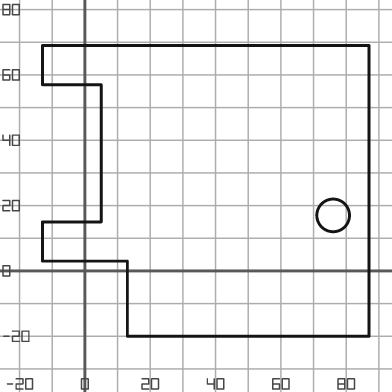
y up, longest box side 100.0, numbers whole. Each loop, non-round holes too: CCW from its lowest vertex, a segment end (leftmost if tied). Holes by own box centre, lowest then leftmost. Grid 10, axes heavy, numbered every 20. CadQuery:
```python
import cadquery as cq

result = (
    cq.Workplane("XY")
    .moveTo(13.0, -20.0)
    .lineTo(87.0, -20.0)
    .lineTo(87.0, 69.0)
    .lineTo(-13.0, 69.0)
    .lineTo(-13.0, 57.0)
    .lineTo(5.0, 57.0)
    .lineTo(5.0, 15.0)
    .lineTo(-13.0, 15.0)
    .lineTo(-13.0, 3.0)
    .lineTo(13.0, 3.0)
    .close()
    .moveTo(76.0, 17.0)
    .circle(5.0)
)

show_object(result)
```